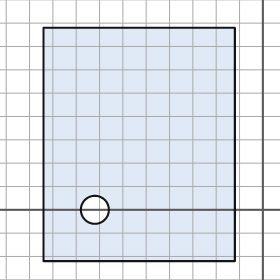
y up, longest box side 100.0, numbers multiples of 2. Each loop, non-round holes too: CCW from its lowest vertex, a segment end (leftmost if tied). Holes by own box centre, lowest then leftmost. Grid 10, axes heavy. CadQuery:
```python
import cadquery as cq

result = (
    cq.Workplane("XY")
    .moveTo(-94.0, -22.0)
    .lineTo(-12.0, -22.0)
    .lineTo(-12.0, 78.0)
    .lineTo(-94.0, 78.0)
    .close()
    .moveTo(-72.0, 0.0)
    .circle(6.0)
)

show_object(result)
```